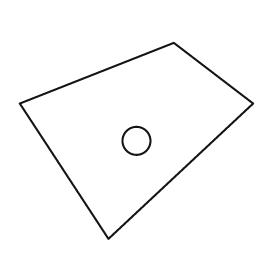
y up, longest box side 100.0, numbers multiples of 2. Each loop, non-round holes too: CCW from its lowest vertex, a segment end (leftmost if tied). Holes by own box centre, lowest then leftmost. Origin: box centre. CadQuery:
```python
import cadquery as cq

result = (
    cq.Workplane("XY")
    .moveTo(-12.0, -42.0)
    .lineTo(50.0, 16.0)
    .lineTo(16.0, 42.0)
    .lineTo(-50.0, 16.0)
    .close()
    .moveTo(0.0, 0.0)
    .circle(6.0)
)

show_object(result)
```